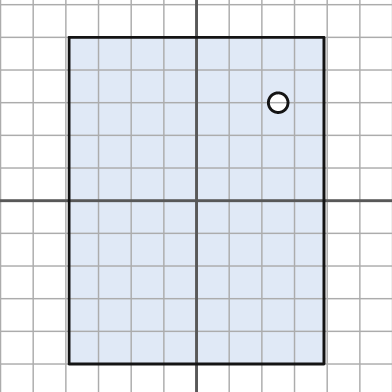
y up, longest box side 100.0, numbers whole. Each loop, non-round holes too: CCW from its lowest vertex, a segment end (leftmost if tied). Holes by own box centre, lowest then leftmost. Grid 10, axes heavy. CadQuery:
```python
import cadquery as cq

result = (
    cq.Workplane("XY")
    .moveTo(-39.0, -50.0)
    .lineTo(39.0, -50.0)
    .lineTo(39.0, 50.0)
    .lineTo(-39.0, 50.0)
    .close()
    .moveTo(25.0, 30.0)
    .circle(3.0)
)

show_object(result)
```